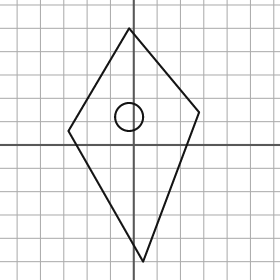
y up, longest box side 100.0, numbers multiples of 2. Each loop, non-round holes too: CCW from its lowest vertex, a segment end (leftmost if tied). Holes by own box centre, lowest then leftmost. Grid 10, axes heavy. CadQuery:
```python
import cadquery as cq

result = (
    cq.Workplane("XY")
    .moveTo(4.0, -50.0)
    .lineTo(28.0, 14.0)
    .lineTo(-2.0, 50.0)
    .lineTo(-28.0, 6.0)
    .close()
    .moveTo(-2.0, 12.0)
    .circle(6.0)
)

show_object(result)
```